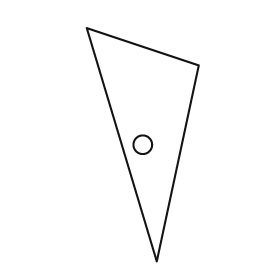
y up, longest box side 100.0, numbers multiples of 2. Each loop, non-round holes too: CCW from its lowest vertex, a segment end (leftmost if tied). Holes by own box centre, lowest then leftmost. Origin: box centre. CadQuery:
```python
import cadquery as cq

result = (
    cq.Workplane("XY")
    .moveTo(6.0, -50.0)
    .lineTo(24.0, 34.0)
    .lineTo(-24.0, 50.0)
    .close()
    .moveTo(0.0, 0.0)
    .circle(4.0)
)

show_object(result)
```